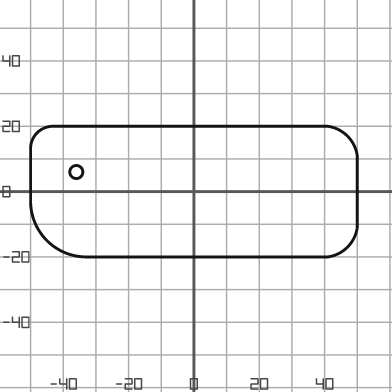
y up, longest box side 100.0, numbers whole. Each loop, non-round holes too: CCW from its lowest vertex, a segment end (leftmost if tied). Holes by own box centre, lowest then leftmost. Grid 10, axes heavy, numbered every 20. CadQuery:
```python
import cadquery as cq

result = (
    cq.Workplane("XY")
    .moveTo(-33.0, -20.0)
    .lineTo(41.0, -20.0)
    .threePointArc((47.0, -17.0), (50.0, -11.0))
    .lineTo(50.0, 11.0)
    .threePointArc((47.0, 17.0), (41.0, 20.0))
    .lineTo(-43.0, 20.0)
    .threePointArc((-48.0, 18.0), (-50.0, 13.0))
    .lineTo(-50.0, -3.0)
    .threePointArc((-45.0, -15.0), (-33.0, -20.0))
    .close()
    .moveTo(-36.0, 6.0)
    .circle(2.0)
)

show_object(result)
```